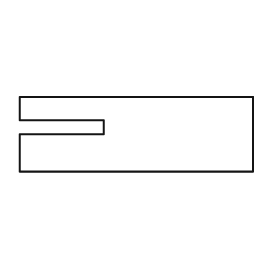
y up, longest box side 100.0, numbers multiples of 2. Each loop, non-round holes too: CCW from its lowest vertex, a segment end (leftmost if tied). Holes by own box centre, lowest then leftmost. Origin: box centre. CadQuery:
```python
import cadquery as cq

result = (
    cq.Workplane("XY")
    .moveTo(-50.0, -16.0)
    .lineTo(50.0, -16.0)
    .lineTo(50.0, 16.0)
    .lineTo(-50.0, 16.0)
    .lineTo(-50.0, 6.0)
    .lineTo(-14.0, 6.0)
    .lineTo(-14.0, 0.0)
    .lineTo(-50.0, 0.0)
    .close()
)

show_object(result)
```